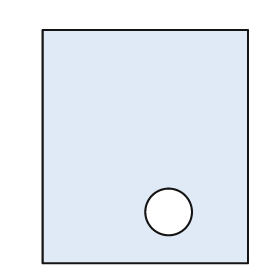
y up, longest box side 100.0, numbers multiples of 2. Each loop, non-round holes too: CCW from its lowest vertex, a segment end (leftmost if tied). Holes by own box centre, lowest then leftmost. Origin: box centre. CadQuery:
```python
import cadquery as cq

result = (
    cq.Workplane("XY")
    .moveTo(-44.0, -50.0)
    .lineTo(44.0, -50.0)
    .lineTo(44.0, 50.0)
    .lineTo(-44.0, 50.0)
    .close()
    .moveTo(10.0, -28.0)
    .circle(10.0)
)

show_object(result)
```